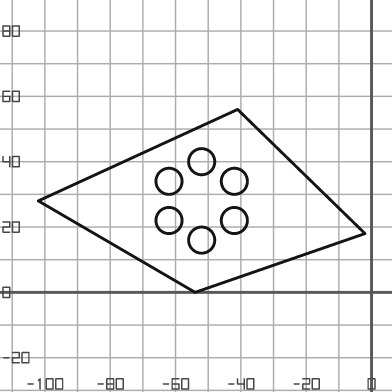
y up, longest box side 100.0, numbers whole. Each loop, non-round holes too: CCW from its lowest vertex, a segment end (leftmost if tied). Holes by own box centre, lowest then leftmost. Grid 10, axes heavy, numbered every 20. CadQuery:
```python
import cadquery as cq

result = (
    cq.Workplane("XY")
    .moveTo(-54.0, 0.0)
    .lineTo(-2.0, 18.0)
    .lineTo(-41.0, 56.0)
    .lineTo(-102.0, 28.0)
    .close()
    .moveTo(-52.0, 16.0)
    .circle(4.0)
    .moveTo(-62.0, 22.0)
    .circle(4.0)
    .moveTo(-42.0, 22.0)
    .circle(4.0)
    .moveTo(-62.0, 34.0)
    .circle(4.0)
    .moveTo(-42.0, 34.0)
    .circle(4.0)
    .moveTo(-52.0, 40.0)
    .circle(4.0)
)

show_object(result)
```